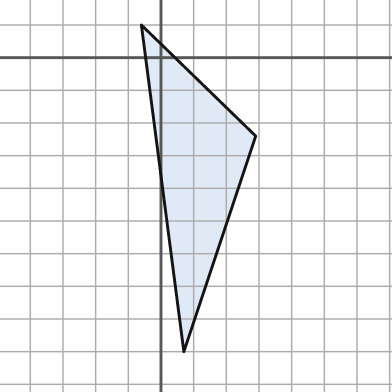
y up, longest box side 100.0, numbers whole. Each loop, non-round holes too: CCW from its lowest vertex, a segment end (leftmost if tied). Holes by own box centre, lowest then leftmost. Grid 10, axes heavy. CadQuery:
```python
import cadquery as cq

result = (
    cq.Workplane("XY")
    .moveTo(7.0, -90.0)
    .lineTo(29.0, -24.0)
    .lineTo(-6.0, 10.0)
    .close()
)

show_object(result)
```